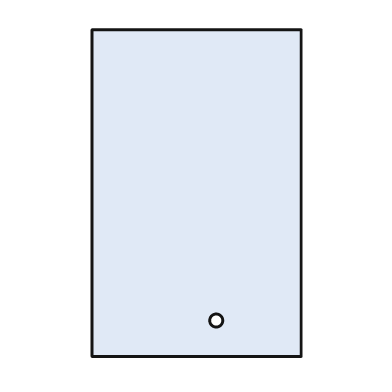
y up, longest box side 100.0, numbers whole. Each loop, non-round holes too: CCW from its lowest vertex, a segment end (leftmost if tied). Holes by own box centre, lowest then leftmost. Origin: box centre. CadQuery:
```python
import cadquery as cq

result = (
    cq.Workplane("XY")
    .moveTo(-32.0, -50.0)
    .lineTo(32.0, -50.0)
    .lineTo(32.0, 50.0)
    .lineTo(-32.0, 50.0)
    .close()
    .moveTo(6.0, -39.0)
    .circle(2.0)
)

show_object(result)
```